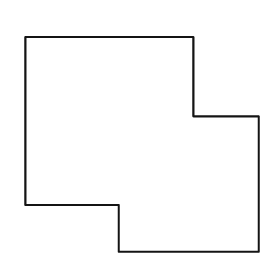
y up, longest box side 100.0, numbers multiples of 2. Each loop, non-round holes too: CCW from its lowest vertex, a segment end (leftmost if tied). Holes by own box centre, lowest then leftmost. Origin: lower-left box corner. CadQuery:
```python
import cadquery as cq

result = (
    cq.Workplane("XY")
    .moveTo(40.0, 0.0)
    .lineTo(100.0, 0.0)
    .lineTo(100.0, 58.0)
    .lineTo(72.0, 58.0)
    .lineTo(72.0, 92.0)
    .lineTo(0.0, 92.0)
    .lineTo(0.0, 20.0)
    .lineTo(40.0, 20.0)
    .close()
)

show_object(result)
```